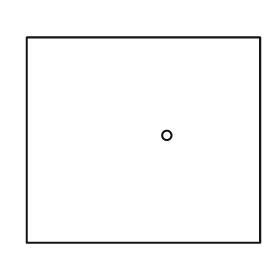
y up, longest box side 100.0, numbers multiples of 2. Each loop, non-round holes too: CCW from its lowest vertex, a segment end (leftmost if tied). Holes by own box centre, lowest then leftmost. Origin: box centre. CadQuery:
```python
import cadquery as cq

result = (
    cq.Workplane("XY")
    .moveTo(-50.0, -44.0)
    .lineTo(50.0, -44.0)
    .lineTo(50.0, 44.0)
    .lineTo(-50.0, 44.0)
    .close()
    .moveTo(10.0, 2.0)
    .circle(2.0)
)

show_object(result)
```